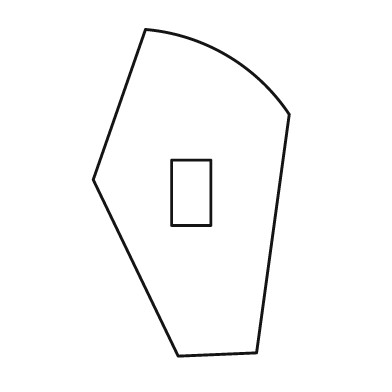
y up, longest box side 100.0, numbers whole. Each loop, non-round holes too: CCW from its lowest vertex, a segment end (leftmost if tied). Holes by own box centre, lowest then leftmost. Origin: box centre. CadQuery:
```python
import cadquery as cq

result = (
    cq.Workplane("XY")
    .moveTo(-4.0, -50.0)
    .lineTo(20.0, -49.0)
    .lineTo(30.0, 24.0)
    .threePointArc((11.0, 42.0), (-14.0, 50.0))
    .lineTo(-30.0, 4.0)
    .close()
    .moveTo(-6.0, -10.0)
    .lineTo(6.0, -10.0)
    .lineTo(6.0, 10.0)
    .lineTo(-6.0, 10.0)
    .close()
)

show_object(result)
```